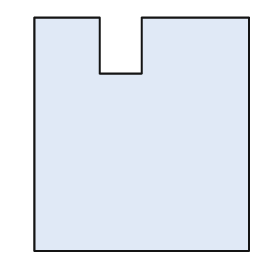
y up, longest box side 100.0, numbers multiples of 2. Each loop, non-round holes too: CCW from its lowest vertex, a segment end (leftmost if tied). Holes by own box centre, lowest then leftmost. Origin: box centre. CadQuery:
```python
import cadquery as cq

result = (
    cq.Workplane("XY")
    .moveTo(-46.0, -50.0)
    .lineTo(46.0, -50.0)
    .lineTo(46.0, 50.0)
    .lineTo(0.0, 50.0)
    .lineTo(0.0, 26.0)
    .lineTo(-18.0, 26.0)
    .lineTo(-18.0, 50.0)
    .lineTo(-46.0, 50.0)
    .close()
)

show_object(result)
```